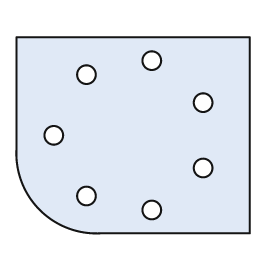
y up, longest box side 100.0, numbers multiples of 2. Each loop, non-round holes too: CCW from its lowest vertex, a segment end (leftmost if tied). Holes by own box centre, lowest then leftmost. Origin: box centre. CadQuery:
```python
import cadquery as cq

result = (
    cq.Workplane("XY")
    .moveTo(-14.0, -42.0)
    .lineTo(50.0, -42.0)
    .lineTo(50.0, 42.0)
    .lineTo(-50.0, 42.0)
    .lineTo(-50.0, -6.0)
    .threePointArc((-40.0, -32.0), (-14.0, -42.0))
    .close()
    .moveTo(8.0, -32.0)
    .circle(4.0)
    .moveTo(-20.0, -26.0)
    .circle(4.0)
    .moveTo(30.0, -14.0)
    .circle(4.0)
    .moveTo(-34.0, 0.0)
    .circle(4.0)
    .moveTo(30.0, 14.0)
    .circle(4.0)
    .moveTo(-20.0, 26.0)
    .circle(4.0)
    .moveTo(8.0, 32.0)
    .circle(4.0)
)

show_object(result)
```